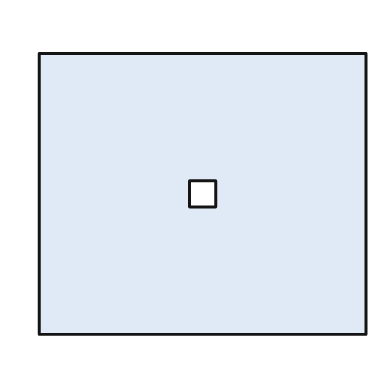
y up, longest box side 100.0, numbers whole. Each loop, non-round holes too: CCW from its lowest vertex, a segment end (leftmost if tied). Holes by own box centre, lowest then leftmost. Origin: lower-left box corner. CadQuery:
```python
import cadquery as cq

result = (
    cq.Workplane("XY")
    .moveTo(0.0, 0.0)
    .lineTo(100.0, 0.0)
    .lineTo(100.0, 86.0)
    .lineTo(0.0, 86.0)
    .close()
    .moveTo(46.0, 39.0)
    .lineTo(54.0, 39.0)
    .lineTo(54.0, 47.0)
    .lineTo(46.0, 47.0)
    .close()
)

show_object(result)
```